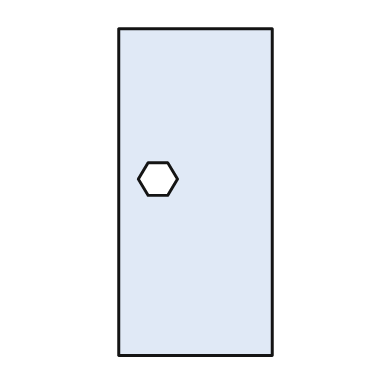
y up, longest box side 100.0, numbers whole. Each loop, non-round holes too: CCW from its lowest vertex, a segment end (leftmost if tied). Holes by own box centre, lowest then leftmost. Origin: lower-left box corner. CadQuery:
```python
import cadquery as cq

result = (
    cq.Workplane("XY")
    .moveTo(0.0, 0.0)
    .lineTo(47.0, 0.0)
    .lineTo(47.0, 100.0)
    .lineTo(0.0, 100.0)
    .close()
    .moveTo(9.0, 49.0)
    .lineTo(15.0, 49.0)
    .lineTo(18.0, 54.0)
    .lineTo(15.0, 59.0)
    .lineTo(9.0, 59.0)
    .lineTo(6.0, 54.0)
    .close()
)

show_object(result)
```